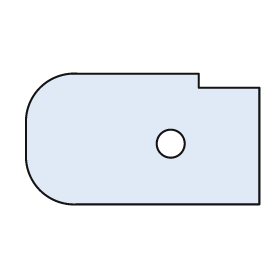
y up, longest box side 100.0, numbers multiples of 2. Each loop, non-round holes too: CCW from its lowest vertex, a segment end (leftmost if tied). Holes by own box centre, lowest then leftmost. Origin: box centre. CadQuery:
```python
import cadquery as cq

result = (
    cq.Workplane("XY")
    .moveTo(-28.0, -28.0)
    .lineTo(50.0, -28.0)
    .lineTo(50.0, 22.0)
    .lineTo(24.0, 22.0)
    .lineTo(24.0, 28.0)
    .lineTo(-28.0, 28.0)
    .threePointArc((-44.0, 22.0), (-50.0, 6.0))
    .lineTo(-50.0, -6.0)
    .threePointArc((-44.0, -22.0), (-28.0, -28.0))
    .close()
    .moveTo(12.0, -2.0)
    .circle(6.0)
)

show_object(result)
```